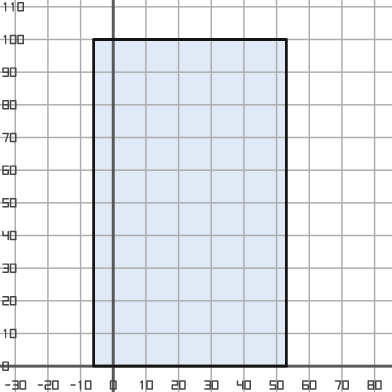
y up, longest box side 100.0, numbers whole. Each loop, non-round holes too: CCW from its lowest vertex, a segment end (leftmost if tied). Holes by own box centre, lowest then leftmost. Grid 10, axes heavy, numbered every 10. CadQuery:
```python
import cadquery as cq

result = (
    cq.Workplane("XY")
    .moveTo(-6.0, 0.0)
    .lineTo(53.0, 0.0)
    .lineTo(53.0, 100.0)
    .lineTo(-6.0, 100.0)
    .close()
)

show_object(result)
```